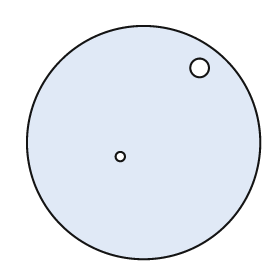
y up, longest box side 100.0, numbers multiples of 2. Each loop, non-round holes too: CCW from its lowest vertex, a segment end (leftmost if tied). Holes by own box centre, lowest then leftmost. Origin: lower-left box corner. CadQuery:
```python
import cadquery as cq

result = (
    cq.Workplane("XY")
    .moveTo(50.0, 50.0)
    .circle(50.0)
    .moveTo(40.0, 44.0)
    .circle(2.0)
    .moveTo(74.0, 82.0)
    .circle(4.0)
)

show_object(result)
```